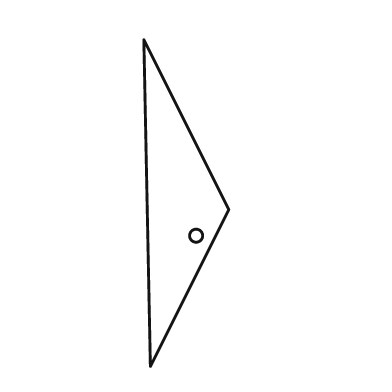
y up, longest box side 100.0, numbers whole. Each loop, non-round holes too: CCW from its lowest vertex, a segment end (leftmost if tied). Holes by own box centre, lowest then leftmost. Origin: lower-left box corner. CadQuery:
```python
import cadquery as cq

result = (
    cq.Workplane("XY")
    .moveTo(2.0, 0.0)
    .lineTo(26.0, 48.0)
    .lineTo(0.0, 100.0)
    .close()
    .moveTo(16.0, 40.0)
    .circle(2.0)
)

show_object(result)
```